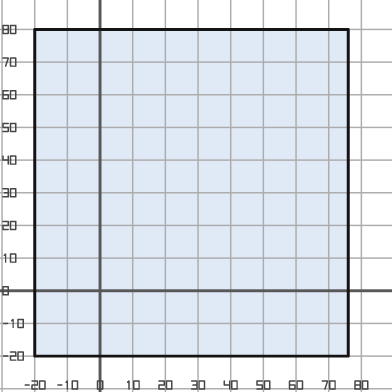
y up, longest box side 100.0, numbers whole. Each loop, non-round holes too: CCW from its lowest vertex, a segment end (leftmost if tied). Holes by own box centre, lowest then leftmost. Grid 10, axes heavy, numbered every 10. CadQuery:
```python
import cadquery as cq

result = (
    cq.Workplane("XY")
    .moveTo(-20.0, -20.0)
    .lineTo(76.0, -20.0)
    .lineTo(76.0, 80.0)
    .lineTo(-20.0, 80.0)
    .close()
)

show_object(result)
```